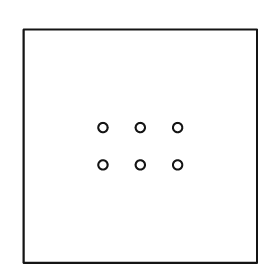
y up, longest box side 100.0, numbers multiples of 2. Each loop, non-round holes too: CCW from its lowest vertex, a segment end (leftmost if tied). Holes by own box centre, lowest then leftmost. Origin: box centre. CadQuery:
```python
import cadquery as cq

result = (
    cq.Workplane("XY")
    .moveTo(-50.0, -50.0)
    .lineTo(50.0, -50.0)
    .lineTo(50.0, 50.0)
    .lineTo(-50.0, 50.0)
    .close()
    .moveTo(-16.0, -8.0)
    .circle(2.0)
    .moveTo(0.0, -8.0)
    .circle(2.0)
    .moveTo(16.0, -8.0)
    .circle(2.0)
    .moveTo(-16.0, 8.0)
    .circle(2.0)
    .moveTo(0.0, 8.0)
    .circle(2.0)
    .moveTo(16.0, 8.0)
    .circle(2.0)
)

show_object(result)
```